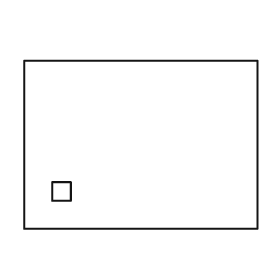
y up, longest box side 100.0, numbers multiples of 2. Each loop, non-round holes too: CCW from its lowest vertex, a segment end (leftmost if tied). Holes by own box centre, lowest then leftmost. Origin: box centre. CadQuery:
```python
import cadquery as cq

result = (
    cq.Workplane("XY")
    .moveTo(-50.0, -36.0)
    .lineTo(50.0, -36.0)
    .lineTo(50.0, 36.0)
    .lineTo(-50.0, 36.0)
    .close()
    .moveTo(-38.0, -24.0)
    .lineTo(-30.0, -24.0)
    .lineTo(-30.0, -16.0)
    .lineTo(-38.0, -16.0)
    .close()
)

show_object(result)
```